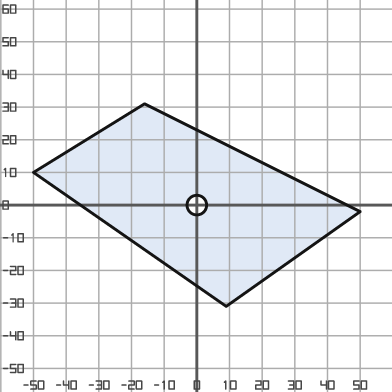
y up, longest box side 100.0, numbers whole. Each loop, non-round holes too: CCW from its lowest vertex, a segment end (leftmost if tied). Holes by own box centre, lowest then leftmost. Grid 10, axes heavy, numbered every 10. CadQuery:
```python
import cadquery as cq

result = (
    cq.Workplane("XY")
    .moveTo(9.0, -31.0)
    .lineTo(50.0, -2.0)
    .lineTo(-16.0, 31.0)
    .lineTo(-50.0, 10.0)
    .close()
    .moveTo(0.0, 0.0)
    .circle(3.0)
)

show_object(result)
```